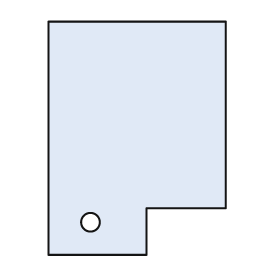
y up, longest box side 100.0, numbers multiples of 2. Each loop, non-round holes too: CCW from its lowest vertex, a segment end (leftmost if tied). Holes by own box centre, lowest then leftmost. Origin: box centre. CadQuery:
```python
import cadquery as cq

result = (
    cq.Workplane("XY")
    .moveTo(-38.0, -50.0)
    .lineTo(4.0, -50.0)
    .lineTo(4.0, -30.0)
    .lineTo(38.0, -30.0)
    .lineTo(38.0, 50.0)
    .lineTo(-38.0, 50.0)
    .close()
    .moveTo(-20.0, -36.0)
    .circle(4.0)
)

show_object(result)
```